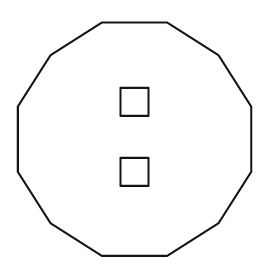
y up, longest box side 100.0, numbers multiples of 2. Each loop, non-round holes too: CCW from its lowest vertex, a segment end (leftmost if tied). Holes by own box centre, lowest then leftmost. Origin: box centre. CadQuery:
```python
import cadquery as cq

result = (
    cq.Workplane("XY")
    .moveTo(-14.0, -50.0)
    .lineTo(14.0, -50.0)
    .lineTo(36.0, -36.0)
    .lineTo(50.0, -14.0)
    .lineTo(50.0, 14.0)
    .lineTo(36.0, 36.0)
    .lineTo(14.0, 50.0)
    .lineTo(-14.0, 50.0)
    .lineTo(-36.0, 36.0)
    .lineTo(-50.0, 14.0)
    .lineTo(-50.0, -14.0)
    .lineTo(-36.0, -36.0)
    .close()
    .moveTo(-6.0, -20.0)
    .lineTo(6.0, -20.0)
    .lineTo(6.0, -8.0)
    .lineTo(-6.0, -8.0)
    .close()
    .moveTo(-6.0, 10.0)
    .lineTo(6.0, 10.0)
    .lineTo(6.0, 22.0)
    .lineTo(-6.0, 22.0)
    .close()
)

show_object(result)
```